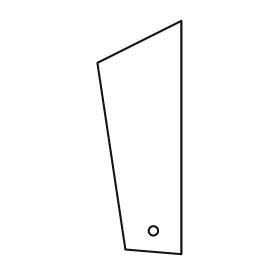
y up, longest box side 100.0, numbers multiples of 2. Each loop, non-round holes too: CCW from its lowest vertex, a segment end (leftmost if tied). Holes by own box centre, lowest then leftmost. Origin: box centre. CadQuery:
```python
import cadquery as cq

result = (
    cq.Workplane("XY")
    .moveTo(18.0, -50.0)
    .lineTo(18.0, 50.0)
    .lineTo(-18.0, 32.0)
    .lineTo(-6.0, -48.0)
    .close()
    .moveTo(6.0, -40.0)
    .circle(2.0)
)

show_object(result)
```